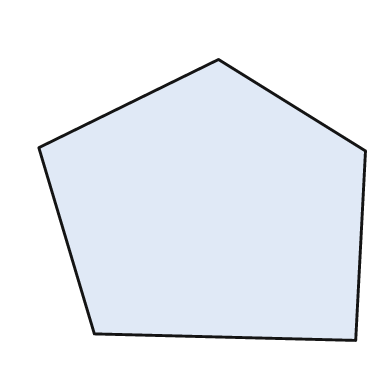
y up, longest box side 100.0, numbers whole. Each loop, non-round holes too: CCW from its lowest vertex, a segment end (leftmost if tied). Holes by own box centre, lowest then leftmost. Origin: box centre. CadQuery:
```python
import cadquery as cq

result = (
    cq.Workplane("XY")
    .moveTo(47.0, -43.0)
    .lineTo(50.0, 15.0)
    .lineTo(5.0, 43.0)
    .lineTo(-50.0, 16.0)
    .lineTo(-33.0, -41.0)
    .close()
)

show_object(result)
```